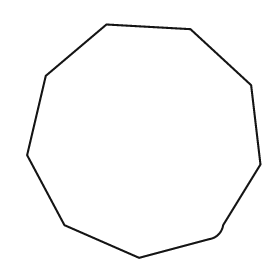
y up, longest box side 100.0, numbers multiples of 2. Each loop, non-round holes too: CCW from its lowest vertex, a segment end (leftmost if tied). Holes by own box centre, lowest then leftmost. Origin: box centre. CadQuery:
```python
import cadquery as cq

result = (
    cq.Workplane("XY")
    .moveTo(-2.0, -50.0)
    .lineTo(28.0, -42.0)
    .threePointArc((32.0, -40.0), (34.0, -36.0))
    .lineTo(50.0, -10.0)
    .lineTo(46.0, 24.0)
    .lineTo(20.0, 48.0)
    .lineTo(-16.0, 50.0)
    .lineTo(-42.0, 28.0)
    .lineTo(-50.0, -6.0)
    .lineTo(-34.0, -36.0)
    .close()
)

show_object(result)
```